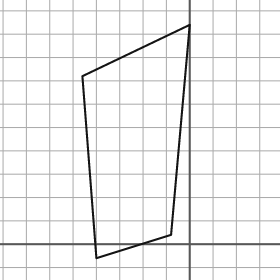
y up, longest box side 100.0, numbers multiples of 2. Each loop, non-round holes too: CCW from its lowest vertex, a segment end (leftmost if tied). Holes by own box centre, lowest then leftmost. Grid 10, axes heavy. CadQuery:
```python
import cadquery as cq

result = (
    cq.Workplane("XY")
    .moveTo(-40.0, -6.0)
    .lineTo(-8.0, 4.0)
    .lineTo(0.0, 94.0)
    .lineTo(-46.0, 72.0)
    .close()
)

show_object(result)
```